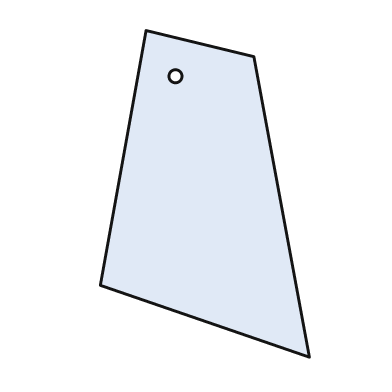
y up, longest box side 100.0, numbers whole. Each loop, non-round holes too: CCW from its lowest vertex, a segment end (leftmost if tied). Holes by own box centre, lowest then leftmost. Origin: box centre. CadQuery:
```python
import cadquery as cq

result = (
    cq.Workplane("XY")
    .moveTo(32.0, -50.0)
    .lineTo(15.0, 42.0)
    .lineTo(-18.0, 50.0)
    .lineTo(-32.0, -28.0)
    .close()
    .moveTo(-9.0, 36.0)
    .circle(2.0)
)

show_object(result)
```